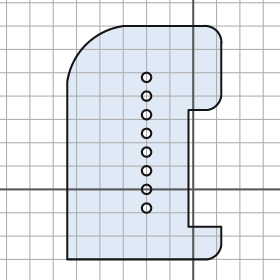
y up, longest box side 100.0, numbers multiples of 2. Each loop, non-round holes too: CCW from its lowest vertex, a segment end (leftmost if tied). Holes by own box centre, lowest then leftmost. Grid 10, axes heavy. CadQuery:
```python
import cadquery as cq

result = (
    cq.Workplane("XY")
    .moveTo(-54.0, -30.0)
    .lineTo(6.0, -30.0)
    .threePointArc((10.0, -28.0), (12.0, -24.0))
    .lineTo(12.0, -16.0)
    .lineTo(-2.0, -16.0)
    .lineTo(-2.0, 34.0)
    .lineTo(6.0, 34.0)
    .threePointArc((10.0, 36.0), (12.0, 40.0))
    .lineTo(12.0, 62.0)
    .threePointArc((10.0, 68.0), (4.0, 70.0))
    .lineTo(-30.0, 70.0)
    .threePointArc((-46.0, 62.0), (-54.0, 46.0))
    .close()
    .moveTo(-20.0, -8.0)
    .circle(2.0)
    .moveTo(-20.0, 0.0)
    .circle(2.0)
    .moveTo(-20.0, 8.0)
    .circle(2.0)
    .moveTo(-20.0, 16.0)
    .circle(2.0)
    .moveTo(-20.0, 24.0)
    .circle(2.0)
    .moveTo(-20.0, 32.0)
    .circle(2.0)
    .moveTo(-20.0, 40.0)
    .circle(2.0)
    .moveTo(-20.0, 48.0)
    .circle(2.0)
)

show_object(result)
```